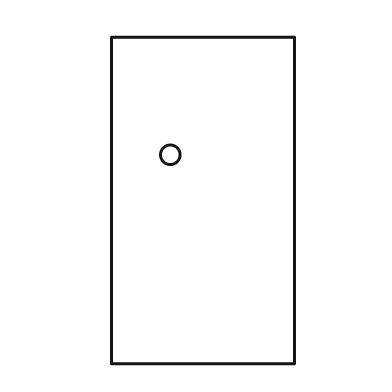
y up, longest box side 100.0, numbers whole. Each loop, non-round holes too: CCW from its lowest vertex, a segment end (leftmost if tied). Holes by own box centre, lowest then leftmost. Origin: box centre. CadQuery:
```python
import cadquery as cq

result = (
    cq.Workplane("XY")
    .moveTo(-28.0, -50.0)
    .lineTo(28.0, -50.0)
    .lineTo(28.0, 50.0)
    .lineTo(-28.0, 50.0)
    .close()
    .moveTo(-10.0, 14.0)
    .circle(3.0)
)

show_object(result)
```